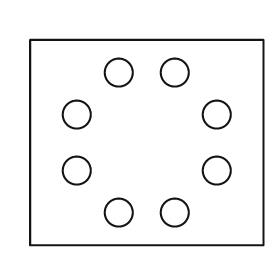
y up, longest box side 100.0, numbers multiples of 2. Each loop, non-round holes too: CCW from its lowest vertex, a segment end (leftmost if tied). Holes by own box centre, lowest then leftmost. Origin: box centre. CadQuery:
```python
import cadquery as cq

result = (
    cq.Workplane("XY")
    .moveTo(-50.0, -44.0)
    .lineTo(50.0, -44.0)
    .lineTo(50.0, 44.0)
    .lineTo(-50.0, 44.0)
    .close()
    .moveTo(-12.0, -30.0)
    .circle(6.0)
    .moveTo(12.0, -30.0)
    .circle(6.0)
    .moveTo(-30.0, -12.0)
    .circle(6.0)
    .moveTo(30.0, -12.0)
    .circle(6.0)
    .moveTo(-30.0, 12.0)
    .circle(6.0)
    .moveTo(30.0, 12.0)
    .circle(6.0)
    .moveTo(-12.0, 30.0)
    .circle(6.0)
    .moveTo(12.0, 30.0)
    .circle(6.0)
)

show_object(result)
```